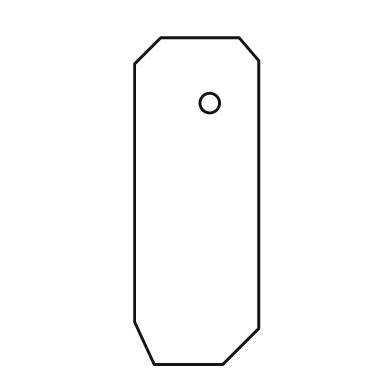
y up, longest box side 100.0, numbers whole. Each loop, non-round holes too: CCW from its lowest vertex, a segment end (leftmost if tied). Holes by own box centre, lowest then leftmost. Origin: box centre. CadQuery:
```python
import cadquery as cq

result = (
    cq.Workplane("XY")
    .moveTo(-13.0, -50.0)
    .lineTo(8.0, -50.0)
    .lineTo(19.0, -39.0)
    .lineTo(19.0, 43.0)
    .lineTo(13.0, 50.0)
    .lineTo(-11.0, 50.0)
    .lineTo(-19.0, 42.0)
    .lineTo(-19.0, -37.0)
    .close()
    .moveTo(4.0, 30.0)
    .circle(3.0)
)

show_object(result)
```